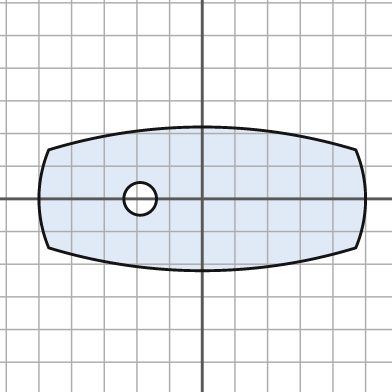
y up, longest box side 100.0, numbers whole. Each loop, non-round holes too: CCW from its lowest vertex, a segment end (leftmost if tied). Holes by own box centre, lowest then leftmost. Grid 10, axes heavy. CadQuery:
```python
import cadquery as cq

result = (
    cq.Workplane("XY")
    .moveTo(-47.0, -15.0)
    .threePointArc((0.0, -22.0), (47.0, -15.0))
    .threePointArc((50.0, 0.0), (47.0, 15.0))
    .threePointArc((0.0, 22.0), (-47.0, 15.0))
    .threePointArc((-50.0, 0.0), (-47.0, -15.0))
    .close()
    .moveTo(-19.0, 0.0)
    .circle(5.0)
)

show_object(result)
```